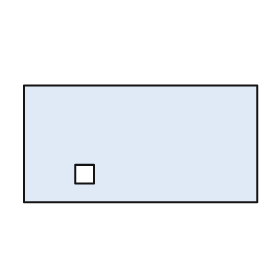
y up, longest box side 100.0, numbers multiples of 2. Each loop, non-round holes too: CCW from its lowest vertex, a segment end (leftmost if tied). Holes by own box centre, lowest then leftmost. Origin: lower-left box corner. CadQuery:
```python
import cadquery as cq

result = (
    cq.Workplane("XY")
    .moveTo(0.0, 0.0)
    .lineTo(100.0, 0.0)
    .lineTo(100.0, 50.0)
    .lineTo(0.0, 50.0)
    .close()
    .moveTo(22.0, 8.0)
    .lineTo(30.0, 8.0)
    .lineTo(30.0, 16.0)
    .lineTo(22.0, 16.0)
    .close()
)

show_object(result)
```